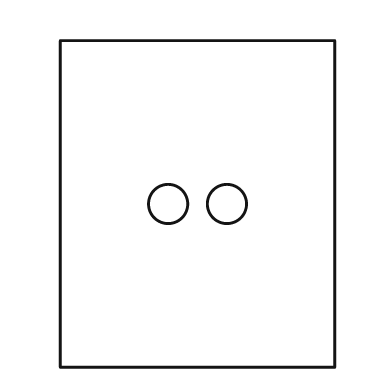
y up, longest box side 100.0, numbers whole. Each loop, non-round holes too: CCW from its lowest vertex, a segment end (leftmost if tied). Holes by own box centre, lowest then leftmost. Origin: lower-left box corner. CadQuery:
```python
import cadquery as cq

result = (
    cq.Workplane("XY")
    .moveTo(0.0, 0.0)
    .lineTo(84.0, 0.0)
    .lineTo(84.0, 100.0)
    .lineTo(0.0, 100.0)
    .close()
    .moveTo(33.0, 50.0)
    .circle(6.0)
    .moveTo(51.0, 50.0)
    .circle(6.0)
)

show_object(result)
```